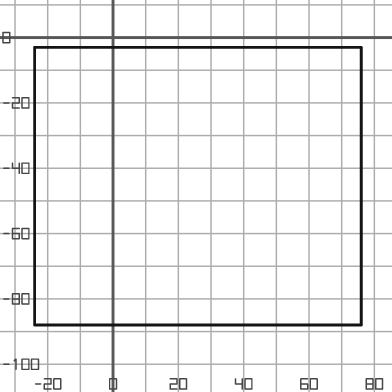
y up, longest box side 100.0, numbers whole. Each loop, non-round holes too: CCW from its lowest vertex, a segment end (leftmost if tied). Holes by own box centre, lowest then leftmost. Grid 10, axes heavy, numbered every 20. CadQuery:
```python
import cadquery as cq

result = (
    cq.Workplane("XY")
    .moveTo(-24.0, -88.0)
    .lineTo(76.0, -88.0)
    .lineTo(76.0, -3.0)
    .lineTo(-24.0, -3.0)
    .close()
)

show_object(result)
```